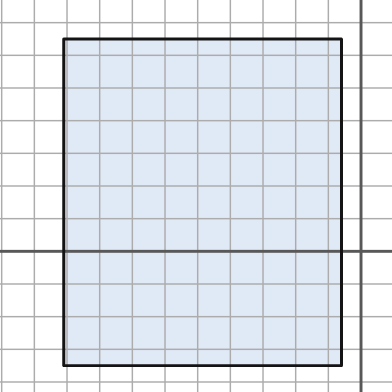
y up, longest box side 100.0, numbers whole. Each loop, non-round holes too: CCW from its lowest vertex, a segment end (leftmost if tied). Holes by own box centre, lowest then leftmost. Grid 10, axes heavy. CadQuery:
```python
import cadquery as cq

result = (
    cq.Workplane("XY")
    .moveTo(-91.0, -35.0)
    .lineTo(-6.0, -35.0)
    .lineTo(-6.0, 65.0)
    .lineTo(-91.0, 65.0)
    .close()
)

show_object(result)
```